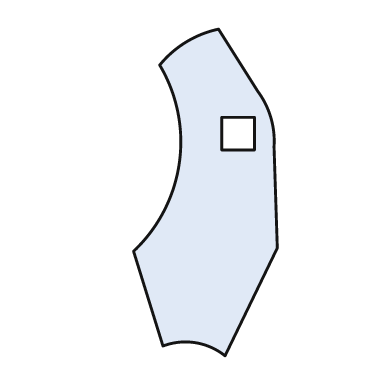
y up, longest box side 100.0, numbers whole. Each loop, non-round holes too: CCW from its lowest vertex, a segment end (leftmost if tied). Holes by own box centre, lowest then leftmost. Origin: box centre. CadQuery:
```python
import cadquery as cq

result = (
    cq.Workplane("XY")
    .moveTo(6.0, -50.0)
    .lineTo(22.0, -17.0)
    .lineTo(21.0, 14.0)
    .threePointArc((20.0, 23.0), (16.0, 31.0))
    .lineTo(4.0, 50.0)
    .threePointArc((-6.0, 46.0), (-14.0, 39.0))
    .threePointArc((-8.0, 9.0), (-22.0, -18.0))
    .lineTo(-13.0, -47.0)
    .threePointArc((-3.0, -46.0), (6.0, -50.0))
    .close()
    .moveTo(5.0, 13.0)
    .lineTo(15.0, 13.0)
    .lineTo(15.0, 23.0)
    .lineTo(5.0, 23.0)
    .close()
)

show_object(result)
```